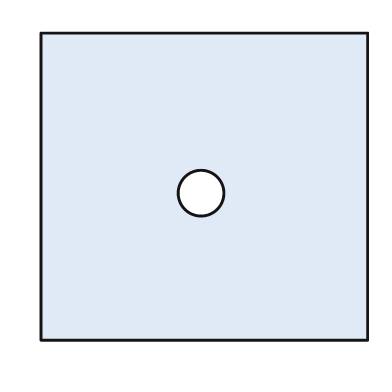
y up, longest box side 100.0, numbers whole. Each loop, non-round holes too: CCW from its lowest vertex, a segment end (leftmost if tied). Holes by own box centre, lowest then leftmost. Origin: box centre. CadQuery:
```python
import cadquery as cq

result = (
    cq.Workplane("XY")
    .moveTo(-50.0, -47.0)
    .lineTo(50.0, -47.0)
    .lineTo(50.0, 47.0)
    .lineTo(-50.0, 47.0)
    .close()
    .moveTo(-1.0, -2.0)
    .circle(7.0)
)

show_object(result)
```